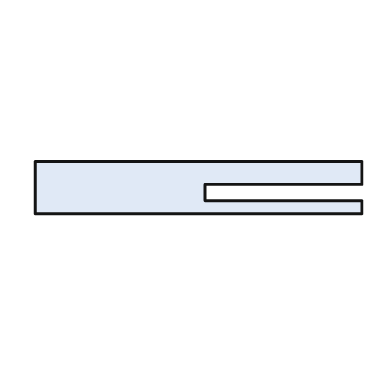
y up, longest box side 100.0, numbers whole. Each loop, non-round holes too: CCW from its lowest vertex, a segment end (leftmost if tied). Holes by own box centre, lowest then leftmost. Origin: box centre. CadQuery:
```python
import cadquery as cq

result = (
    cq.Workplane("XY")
    .moveTo(-50.0, -8.0)
    .lineTo(50.0, -8.0)
    .lineTo(50.0, -4.0)
    .lineTo(2.0, -4.0)
    .lineTo(2.0, 1.0)
    .lineTo(50.0, 1.0)
    .lineTo(50.0, 8.0)
    .lineTo(-50.0, 8.0)
    .close()
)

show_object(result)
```